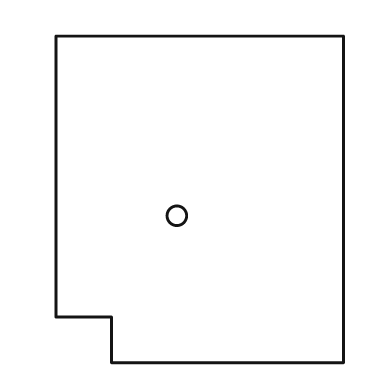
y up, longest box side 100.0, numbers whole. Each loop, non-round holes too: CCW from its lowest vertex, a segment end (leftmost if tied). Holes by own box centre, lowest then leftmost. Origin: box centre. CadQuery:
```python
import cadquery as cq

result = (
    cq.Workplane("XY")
    .moveTo(-27.0, -50.0)
    .lineTo(44.0, -50.0)
    .lineTo(44.0, 50.0)
    .lineTo(-44.0, 50.0)
    .lineTo(-44.0, -36.0)
    .lineTo(-27.0, -36.0)
    .close()
    .moveTo(-7.0, -5.0)
    .circle(3.0)
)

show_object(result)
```